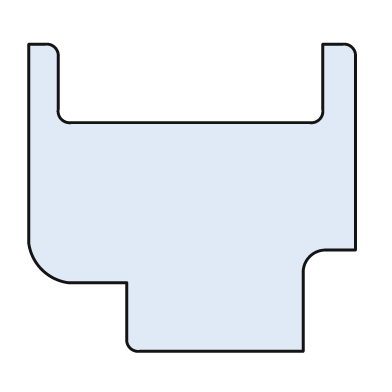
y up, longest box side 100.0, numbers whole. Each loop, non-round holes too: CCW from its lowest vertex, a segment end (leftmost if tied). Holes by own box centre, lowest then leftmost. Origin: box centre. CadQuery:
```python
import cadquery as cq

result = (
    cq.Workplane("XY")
    .moveTo(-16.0, -47.0)
    .lineTo(34.0, -47.0)
    .lineTo(34.0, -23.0)
    .threePointArc((36.0, -18.0), (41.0, -16.0))
    .lineTo(50.0, -16.0)
    .lineTo(50.0, 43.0)
    .threePointArc((49.0, 46.0), (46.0, 47.0))
    .lineTo(40.0, 47.0)
    .lineTo(40.0, 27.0)
    .threePointArc((39.0, 24.0), (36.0, 23.0))
    .lineTo(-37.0, 23.0)
    .threePointArc((-40.0, 24.0), (-41.0, 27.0))
    .lineTo(-41.0, 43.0)
    .threePointArc((-42.0, 46.0), (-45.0, 47.0))
    .lineTo(-50.0, 47.0)
    .lineTo(-50.0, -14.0)
    .threePointArc((-46.0, -22.0), (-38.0, -26.0))
    .lineTo(-20.0, -26.0)
    .lineTo(-20.0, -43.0)
    .threePointArc((-19.0, -46.0), (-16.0, -47.0))
    .close()
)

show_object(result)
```